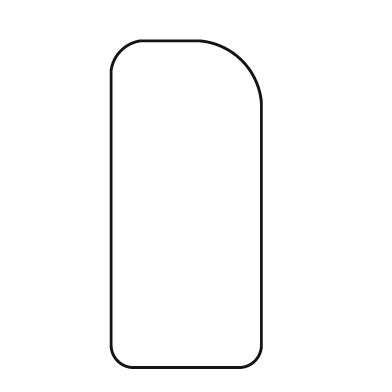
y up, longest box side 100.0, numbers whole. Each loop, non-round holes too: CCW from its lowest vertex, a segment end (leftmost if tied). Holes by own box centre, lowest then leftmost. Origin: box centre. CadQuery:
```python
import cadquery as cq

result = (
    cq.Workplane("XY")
    .moveTo(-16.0, -50.0)
    .lineTo(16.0, -50.0)
    .threePointArc((21.0, -48.0), (23.0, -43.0))
    .lineTo(23.0, 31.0)
    .threePointArc((17.0, 44.0), (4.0, 50.0))
    .lineTo(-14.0, 50.0)
    .threePointArc((-20.0, 47.0), (-23.0, 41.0))
    .lineTo(-23.0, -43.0)
    .threePointArc((-21.0, -48.0), (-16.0, -50.0))
    .close()
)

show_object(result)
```